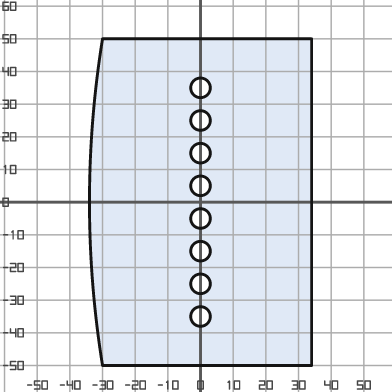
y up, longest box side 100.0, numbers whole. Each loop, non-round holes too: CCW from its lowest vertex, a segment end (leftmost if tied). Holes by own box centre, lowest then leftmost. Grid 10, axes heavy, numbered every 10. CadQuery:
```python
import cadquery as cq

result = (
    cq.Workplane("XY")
    .moveTo(-30.0, -50.0)
    .lineTo(34.0, -50.0)
    .lineTo(34.0, 50.0)
    .lineTo(-30.0, 50.0)
    .threePointArc((-34.0, 0.0), (-30.0, -50.0))
    .close()
    .moveTo(0.0, -35.0)
    .circle(3.0)
    .moveTo(0.0, -25.0)
    .circle(3.0)
    .moveTo(0.0, -15.0)
    .circle(3.0)
    .moveTo(0.0, -5.0)
    .circle(3.0)
    .moveTo(0.0, 5.0)
    .circle(3.0)
    .moveTo(0.0, 15.0)
    .circle(3.0)
    .moveTo(0.0, 25.0)
    .circle(3.0)
    .moveTo(0.0, 35.0)
    .circle(3.0)
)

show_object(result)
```